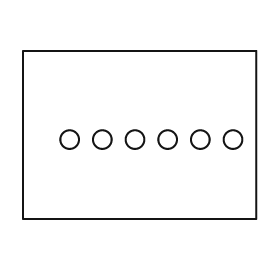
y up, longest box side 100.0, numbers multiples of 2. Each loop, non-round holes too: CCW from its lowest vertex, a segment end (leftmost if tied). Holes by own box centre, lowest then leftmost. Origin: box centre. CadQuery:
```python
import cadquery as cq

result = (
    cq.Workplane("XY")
    .moveTo(-50.0, -36.0)
    .lineTo(50.0, -36.0)
    .lineTo(50.0, 36.0)
    .lineTo(-50.0, 36.0)
    .close()
    .moveTo(-30.0, -2.0)
    .circle(4.0)
    .moveTo(-16.0, -2.0)
    .circle(4.0)
    .moveTo(-2.0, -2.0)
    .circle(4.0)
    .moveTo(12.0, -2.0)
    .circle(4.0)
    .moveTo(26.0, -2.0)
    .circle(4.0)
    .moveTo(40.0, -2.0)
    .circle(4.0)
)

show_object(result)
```